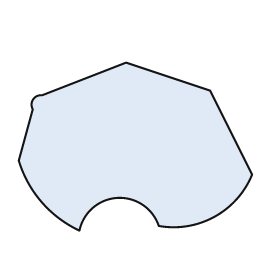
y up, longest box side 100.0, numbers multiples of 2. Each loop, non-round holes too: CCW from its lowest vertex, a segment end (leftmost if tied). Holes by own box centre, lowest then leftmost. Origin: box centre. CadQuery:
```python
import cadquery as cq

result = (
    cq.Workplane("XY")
    .moveTo(-24.0, -36.0)
    .threePointArc((-8.0, -22.0), (10.0, -34.0))
    .threePointArc((34.0, -30.0), (50.0, -12.0))
    .lineTo(32.0, 24.0)
    .lineTo(-4.0, 36.0)
    .lineTo(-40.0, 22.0)
    .threePointArc((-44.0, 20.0), (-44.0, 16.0))
    .lineTo(-50.0, -6.0)
    .threePointArc((-40.0, -24.0), (-24.0, -36.0))
    .close()
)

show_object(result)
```